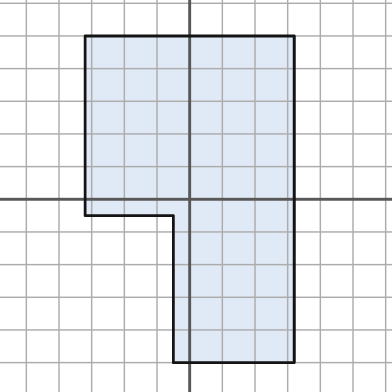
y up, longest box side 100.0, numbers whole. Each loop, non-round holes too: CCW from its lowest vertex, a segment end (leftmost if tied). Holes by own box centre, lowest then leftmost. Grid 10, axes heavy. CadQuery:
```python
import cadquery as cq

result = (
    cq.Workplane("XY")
    .moveTo(-5.0, -50.0)
    .lineTo(32.0, -50.0)
    .lineTo(32.0, 50.0)
    .lineTo(-32.0, 50.0)
    .lineTo(-32.0, -5.0)
    .lineTo(-5.0, -5.0)
    .close()
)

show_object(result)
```